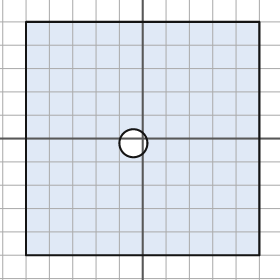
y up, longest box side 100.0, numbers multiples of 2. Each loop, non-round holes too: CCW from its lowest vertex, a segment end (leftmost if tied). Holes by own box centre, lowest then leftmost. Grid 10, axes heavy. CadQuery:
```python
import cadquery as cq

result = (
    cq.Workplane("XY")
    .moveTo(-50.0, -50.0)
    .lineTo(50.0, -50.0)
    .lineTo(50.0, 50.0)
    .lineTo(-50.0, 50.0)
    .close()
    .moveTo(-4.0, -2.0)
    .circle(6.0)
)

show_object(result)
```